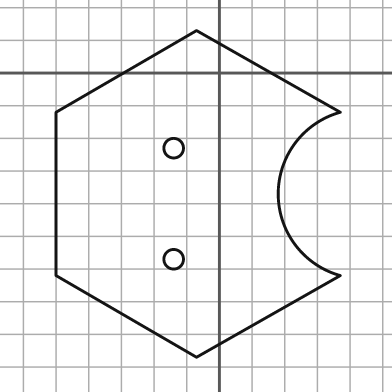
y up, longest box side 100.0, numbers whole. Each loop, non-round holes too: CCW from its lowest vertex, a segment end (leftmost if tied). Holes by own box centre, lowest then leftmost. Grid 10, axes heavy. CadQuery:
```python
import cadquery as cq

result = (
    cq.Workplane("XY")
    .moveTo(-7.0, -87.0)
    .lineTo(37.0, -62.0)
    .threePointArc((18.0, -37.0), (37.0, -12.0))
    .lineTo(-7.0, 13.0)
    .lineTo(-50.0, -12.0)
    .lineTo(-50.0, -62.0)
    .close()
    .moveTo(-14.0, -57.0)
    .circle(3.0)
    .moveTo(-14.0, -23.0)
    .circle(3.0)
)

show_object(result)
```